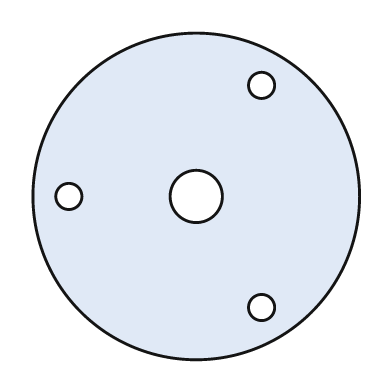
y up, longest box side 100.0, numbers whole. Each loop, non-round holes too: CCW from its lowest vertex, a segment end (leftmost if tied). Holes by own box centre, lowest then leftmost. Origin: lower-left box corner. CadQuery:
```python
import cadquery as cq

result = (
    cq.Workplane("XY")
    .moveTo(50.0, 50.0)
    .circle(50.0)
    .moveTo(70.0, 16.0)
    .circle(4.0)
    .moveTo(11.0, 50.0)
    .circle(4.0)
    .moveTo(50.0, 50.0)
    .circle(8.0)
    .moveTo(70.0, 84.0)
    .circle(4.0)
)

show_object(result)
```